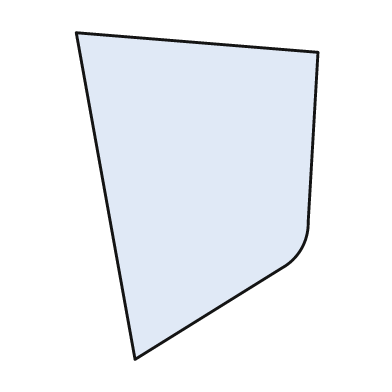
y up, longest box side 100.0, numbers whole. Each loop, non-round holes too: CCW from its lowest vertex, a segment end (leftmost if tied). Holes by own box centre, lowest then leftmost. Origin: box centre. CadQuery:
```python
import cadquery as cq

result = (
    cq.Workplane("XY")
    .moveTo(-19.0, -50.0)
    .lineTo(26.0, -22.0)
    .threePointArc((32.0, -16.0), (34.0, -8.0))
    .lineTo(37.0, 44.0)
    .lineTo(-37.0, 50.0)
    .close()
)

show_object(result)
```